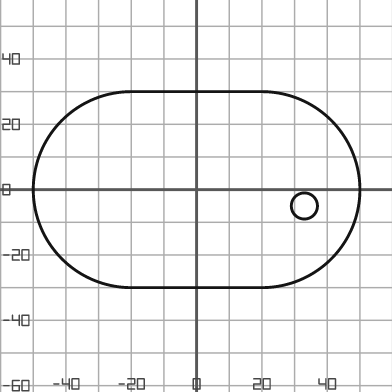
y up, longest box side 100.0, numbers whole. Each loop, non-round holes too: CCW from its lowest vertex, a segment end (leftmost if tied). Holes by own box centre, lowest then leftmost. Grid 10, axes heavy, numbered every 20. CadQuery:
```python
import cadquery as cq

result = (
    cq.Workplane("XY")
    .moveTo(-20.0, -30.0)
    .lineTo(20.0, -30.0)
    .threePointArc((50.0, 0.0), (20.0, 30.0))
    .lineTo(-20.0, 30.0)
    .threePointArc((-50.0, 0.0), (-20.0, -30.0))
    .close()
    .moveTo(33.0, -5.0)
    .circle(4.0)
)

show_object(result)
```